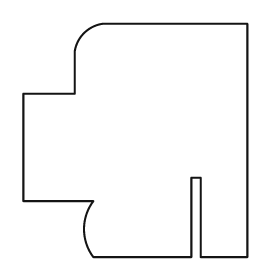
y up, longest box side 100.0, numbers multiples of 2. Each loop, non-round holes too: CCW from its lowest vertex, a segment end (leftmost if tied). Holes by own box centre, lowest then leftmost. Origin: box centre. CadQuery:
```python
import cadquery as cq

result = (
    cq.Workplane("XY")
    .moveTo(-18.0, -50.0)
    .lineTo(24.0, -50.0)
    .lineTo(24.0, -16.0)
    .lineTo(28.0, -16.0)
    .lineTo(28.0, -50.0)
    .lineTo(48.0, -50.0)
    .lineTo(48.0, 50.0)
    .lineTo(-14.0, 50.0)
    .threePointArc((-22.0, 46.0), (-26.0, 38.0))
    .lineTo(-26.0, 20.0)
    .lineTo(-48.0, 20.0)
    .lineTo(-48.0, -26.0)
    .lineTo(-18.0, -26.0)
    .threePointArc((-22.0, -38.0), (-18.0, -50.0))
    .close()
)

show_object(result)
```